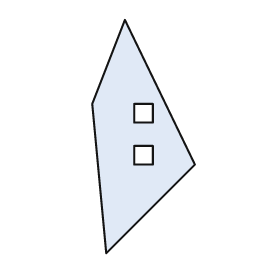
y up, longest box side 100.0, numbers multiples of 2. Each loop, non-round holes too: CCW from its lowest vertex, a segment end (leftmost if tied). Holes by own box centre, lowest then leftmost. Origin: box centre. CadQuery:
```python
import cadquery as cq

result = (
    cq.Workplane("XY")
    .moveTo(-16.0, -50.0)
    .lineTo(22.0, -12.0)
    .lineTo(-8.0, 50.0)
    .lineTo(-22.0, 14.0)
    .close()
    .moveTo(-4.0, -12.0)
    .lineTo(4.0, -12.0)
    .lineTo(4.0, -4.0)
    .lineTo(-4.0, -4.0)
    .close()
    .moveTo(-4.0, 6.0)
    .lineTo(4.0, 6.0)
    .lineTo(4.0, 14.0)
    .lineTo(-4.0, 14.0)
    .close()
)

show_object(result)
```